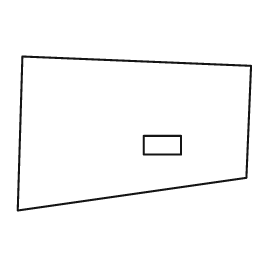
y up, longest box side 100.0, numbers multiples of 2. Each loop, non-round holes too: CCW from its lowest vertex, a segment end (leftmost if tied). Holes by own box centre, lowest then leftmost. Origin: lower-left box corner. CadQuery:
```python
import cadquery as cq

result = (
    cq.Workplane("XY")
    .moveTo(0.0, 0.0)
    .lineTo(98.0, 14.0)
    .lineTo(100.0, 62.0)
    .lineTo(2.0, 66.0)
    .close()
    .moveTo(54.0, 24.0)
    .lineTo(70.0, 24.0)
    .lineTo(70.0, 32.0)
    .lineTo(54.0, 32.0)
    .close()
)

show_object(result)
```